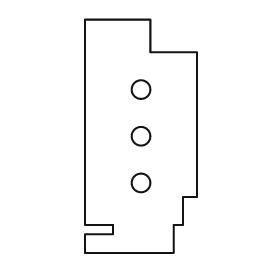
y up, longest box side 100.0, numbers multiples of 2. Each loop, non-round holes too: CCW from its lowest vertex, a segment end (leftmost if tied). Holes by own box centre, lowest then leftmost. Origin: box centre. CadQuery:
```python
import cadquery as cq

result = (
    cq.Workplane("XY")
    .moveTo(-24.0, -50.0)
    .lineTo(14.0, -50.0)
    .lineTo(14.0, -38.0)
    .lineTo(18.0, -38.0)
    .lineTo(18.0, -26.0)
    .lineTo(24.0, -26.0)
    .lineTo(24.0, 36.0)
    .lineTo(4.0, 36.0)
    .lineTo(4.0, 50.0)
    .lineTo(-24.0, 50.0)
    .lineTo(-24.0, -38.0)
    .lineTo(-12.0, -38.0)
    .lineTo(-12.0, -42.0)
    .lineTo(-24.0, -42.0)
    .close()
    .moveTo(0.0, -20.0)
    .circle(4.0)
    .moveTo(0.0, 0.0)
    .circle(4.0)
    .moveTo(0.0, 20.0)
    .circle(4.0)
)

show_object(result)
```